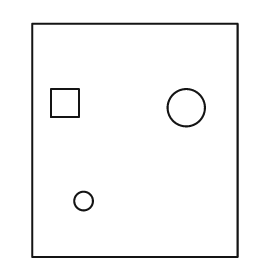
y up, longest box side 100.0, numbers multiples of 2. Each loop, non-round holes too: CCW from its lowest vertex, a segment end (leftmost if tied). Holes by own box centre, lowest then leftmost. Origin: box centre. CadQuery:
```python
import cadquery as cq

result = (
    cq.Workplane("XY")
    .moveTo(-44.0, -50.0)
    .lineTo(44.0, -50.0)
    .lineTo(44.0, 50.0)
    .lineTo(-44.0, 50.0)
    .close()
    .moveTo(-22.0, -26.0)
    .circle(4.0)
    .moveTo(22.0, 14.0)
    .circle(8.0)
    .moveTo(-36.0, 10.0)
    .lineTo(-24.0, 10.0)
    .lineTo(-24.0, 22.0)
    .lineTo(-36.0, 22.0)
    .close()
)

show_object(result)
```